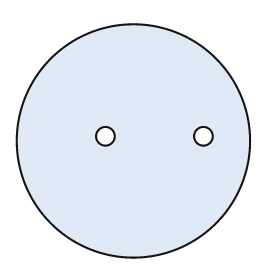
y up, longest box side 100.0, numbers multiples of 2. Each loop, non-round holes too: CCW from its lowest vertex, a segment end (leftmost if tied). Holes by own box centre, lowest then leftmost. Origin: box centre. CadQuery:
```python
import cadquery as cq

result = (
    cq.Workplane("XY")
    .moveTo(0.0, 0.0)
    .circle(50.0)
    .moveTo(-12.0, 2.0)
    .circle(4.0)
    .moveTo(30.0, 2.0)
    .circle(4.0)
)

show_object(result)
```